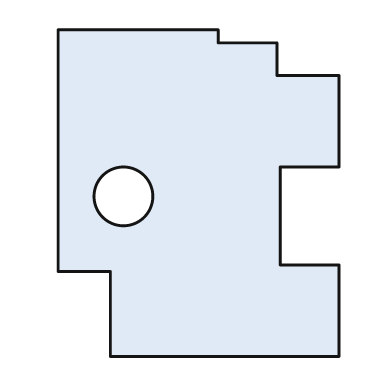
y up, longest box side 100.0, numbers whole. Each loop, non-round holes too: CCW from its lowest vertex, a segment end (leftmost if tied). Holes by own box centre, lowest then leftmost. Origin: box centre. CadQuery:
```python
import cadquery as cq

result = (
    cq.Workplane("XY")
    .moveTo(-27.0, -50.0)
    .lineTo(43.0, -50.0)
    .lineTo(43.0, -22.0)
    .lineTo(25.0, -22.0)
    .lineTo(25.0, 8.0)
    .lineTo(43.0, 8.0)
    .lineTo(43.0, 36.0)
    .lineTo(24.0, 36.0)
    .lineTo(24.0, 46.0)
    .lineTo(6.0, 46.0)
    .lineTo(6.0, 50.0)
    .lineTo(-43.0, 50.0)
    .lineTo(-43.0, -24.0)
    .lineTo(-27.0, -24.0)
    .close()
    .moveTo(-23.0, -1.0)
    .circle(9.0)
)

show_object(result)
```